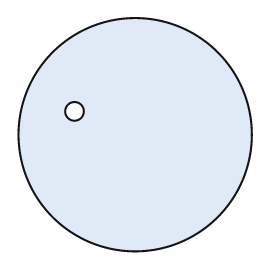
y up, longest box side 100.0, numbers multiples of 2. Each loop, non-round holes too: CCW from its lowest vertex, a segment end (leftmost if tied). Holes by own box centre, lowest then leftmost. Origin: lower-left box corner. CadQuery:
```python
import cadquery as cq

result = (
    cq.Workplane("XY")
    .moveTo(50.0, 50.0)
    .circle(50.0)
    .moveTo(24.0, 60.0)
    .circle(4.0)
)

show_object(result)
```